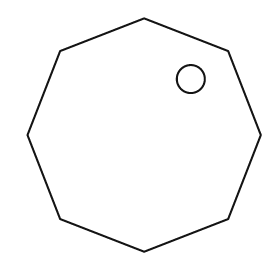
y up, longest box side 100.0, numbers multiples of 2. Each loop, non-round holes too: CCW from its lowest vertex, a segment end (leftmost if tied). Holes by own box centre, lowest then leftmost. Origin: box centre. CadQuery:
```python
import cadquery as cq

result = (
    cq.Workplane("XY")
    .moveTo(0.0, -50.0)
    .lineTo(36.0, -36.0)
    .lineTo(50.0, 0.0)
    .lineTo(36.0, 36.0)
    .lineTo(0.0, 50.0)
    .lineTo(-36.0, 36.0)
    .lineTo(-50.0, 0.0)
    .lineTo(-36.0, -36.0)
    .close()
    .moveTo(20.0, 24.0)
    .circle(6.0)
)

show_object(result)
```